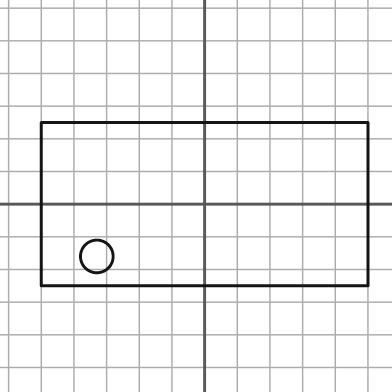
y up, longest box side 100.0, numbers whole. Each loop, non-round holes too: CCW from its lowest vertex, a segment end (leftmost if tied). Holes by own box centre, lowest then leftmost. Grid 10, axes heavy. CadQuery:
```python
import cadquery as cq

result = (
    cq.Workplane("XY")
    .moveTo(-50.0, -25.0)
    .lineTo(50.0, -25.0)
    .lineTo(50.0, 25.0)
    .lineTo(-50.0, 25.0)
    .close()
    .moveTo(-33.0, -16.0)
    .circle(5.0)
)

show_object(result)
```